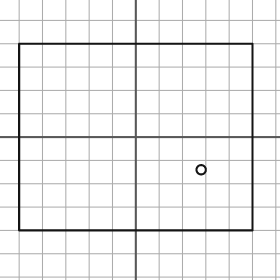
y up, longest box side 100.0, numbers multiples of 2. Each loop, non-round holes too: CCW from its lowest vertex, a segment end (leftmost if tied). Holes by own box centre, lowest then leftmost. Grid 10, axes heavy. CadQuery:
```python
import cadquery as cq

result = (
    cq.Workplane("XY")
    .moveTo(-50.0, -40.0)
    .lineTo(50.0, -40.0)
    .lineTo(50.0, 40.0)
    .lineTo(-50.0, 40.0)
    .close()
    .moveTo(28.0, -14.0)
    .circle(2.0)
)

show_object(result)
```